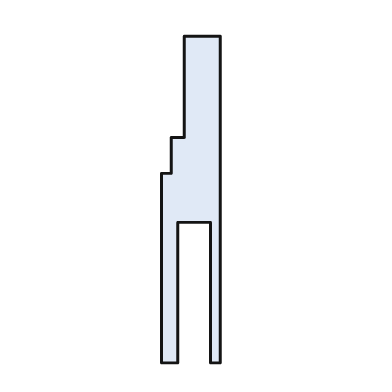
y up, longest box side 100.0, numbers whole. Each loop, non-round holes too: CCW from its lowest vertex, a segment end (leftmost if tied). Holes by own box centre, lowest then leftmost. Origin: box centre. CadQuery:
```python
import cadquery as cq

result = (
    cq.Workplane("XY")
    .moveTo(-9.0, -50.0)
    .lineTo(-4.0, -50.0)
    .lineTo(-4.0, -7.0)
    .lineTo(6.0, -7.0)
    .lineTo(6.0, -50.0)
    .lineTo(9.0, -50.0)
    .lineTo(9.0, 50.0)
    .lineTo(-2.0, 50.0)
    .lineTo(-2.0, 19.0)
    .lineTo(-6.0, 19.0)
    .lineTo(-6.0, 8.0)
    .lineTo(-9.0, 8.0)
    .close()
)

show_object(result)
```